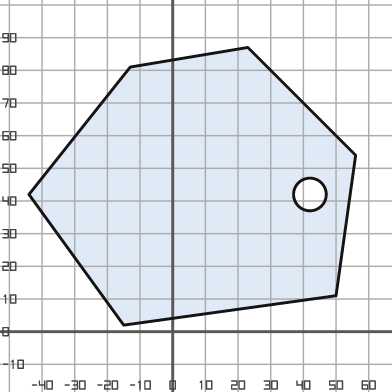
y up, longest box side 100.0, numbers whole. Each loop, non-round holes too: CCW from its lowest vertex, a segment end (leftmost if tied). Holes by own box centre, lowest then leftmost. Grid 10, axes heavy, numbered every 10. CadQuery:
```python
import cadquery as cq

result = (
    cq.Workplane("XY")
    .moveTo(-15.0, 2.0)
    .lineTo(50.0, 11.0)
    .lineTo(56.0, 54.0)
    .lineTo(23.0, 87.0)
    .lineTo(-13.0, 81.0)
    .lineTo(-44.0, 42.0)
    .close()
    .moveTo(42.0, 42.0)
    .circle(5.0)
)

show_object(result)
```